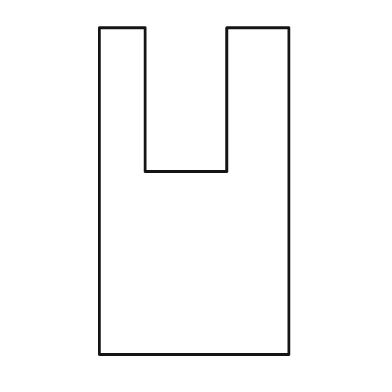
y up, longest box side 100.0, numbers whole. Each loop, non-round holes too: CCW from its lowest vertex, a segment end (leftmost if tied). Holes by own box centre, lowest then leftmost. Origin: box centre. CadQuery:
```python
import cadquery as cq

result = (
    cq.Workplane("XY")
    .moveTo(-29.0, -50.0)
    .lineTo(29.0, -50.0)
    .lineTo(29.0, 50.0)
    .lineTo(10.0, 50.0)
    .lineTo(10.0, 6.0)
    .lineTo(-15.0, 6.0)
    .lineTo(-15.0, 50.0)
    .lineTo(-29.0, 50.0)
    .close()
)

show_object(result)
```